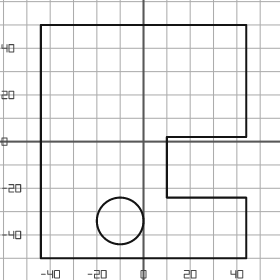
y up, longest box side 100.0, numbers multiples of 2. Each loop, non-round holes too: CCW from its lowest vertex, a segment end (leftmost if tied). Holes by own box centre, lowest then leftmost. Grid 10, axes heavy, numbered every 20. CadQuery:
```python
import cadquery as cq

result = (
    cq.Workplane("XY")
    .moveTo(-44.0, -50.0)
    .lineTo(44.0, -50.0)
    .lineTo(44.0, -24.0)
    .lineTo(10.0, -24.0)
    .lineTo(10.0, 2.0)
    .lineTo(44.0, 2.0)
    .lineTo(44.0, 50.0)
    .lineTo(-44.0, 50.0)
    .close()
    .moveTo(-10.0, -34.0)
    .circle(10.0)
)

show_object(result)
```